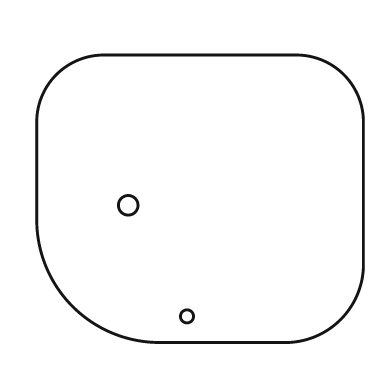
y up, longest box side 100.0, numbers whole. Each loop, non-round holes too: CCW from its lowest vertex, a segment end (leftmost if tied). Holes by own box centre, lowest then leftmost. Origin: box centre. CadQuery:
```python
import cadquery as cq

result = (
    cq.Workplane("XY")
    .moveTo(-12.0, -44.0)
    .lineTo(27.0, -44.0)
    .threePointArc((43.0, -37.0), (50.0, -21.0))
    .lineTo(50.0, 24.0)
    .threePointArc((44.0, 38.0), (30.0, 44.0))
    .lineTo(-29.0, 44.0)
    .threePointArc((-44.0, 38.0), (-50.0, 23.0))
    .lineTo(-50.0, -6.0)
    .threePointArc((-39.0, -33.0), (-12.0, -44.0))
    .close()
    .moveTo(-4.0, -36.0)
    .circle(2.0)
    .moveTo(-22.0, -2.0)
    .circle(3.0)
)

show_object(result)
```